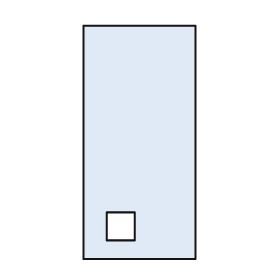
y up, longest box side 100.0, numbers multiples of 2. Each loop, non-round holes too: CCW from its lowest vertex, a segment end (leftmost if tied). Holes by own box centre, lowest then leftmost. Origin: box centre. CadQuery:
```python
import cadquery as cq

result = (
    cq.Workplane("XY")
    .moveTo(-24.0, -50.0)
    .lineTo(24.0, -50.0)
    .lineTo(24.0, 50.0)
    .lineTo(-24.0, 50.0)
    .close()
    .moveTo(-14.0, -42.0)
    .lineTo(-2.0, -42.0)
    .lineTo(-2.0, -30.0)
    .lineTo(-14.0, -30.0)
    .close()
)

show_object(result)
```